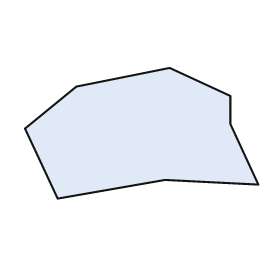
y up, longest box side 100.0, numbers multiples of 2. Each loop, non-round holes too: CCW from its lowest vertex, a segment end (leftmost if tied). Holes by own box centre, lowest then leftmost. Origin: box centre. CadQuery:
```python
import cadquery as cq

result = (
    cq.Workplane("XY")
    .moveTo(-36.0, -28.0)
    .lineTo(10.0, -20.0)
    .lineTo(50.0, -22.0)
    .lineTo(38.0, 4.0)
    .lineTo(38.0, 16.0)
    .lineTo(12.0, 28.0)
    .lineTo(-28.0, 20.0)
    .lineTo(-50.0, 2.0)
    .close()
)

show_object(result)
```